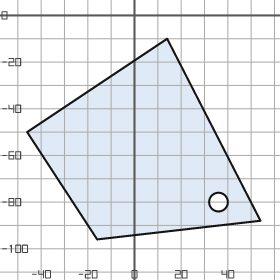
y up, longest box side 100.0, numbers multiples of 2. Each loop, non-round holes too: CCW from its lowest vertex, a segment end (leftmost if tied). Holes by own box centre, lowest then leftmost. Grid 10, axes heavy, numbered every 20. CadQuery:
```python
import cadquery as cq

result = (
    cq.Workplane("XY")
    .moveTo(-16.0, -96.0)
    .lineTo(54.0, -88.0)
    .lineTo(14.0, -10.0)
    .lineTo(-46.0, -50.0)
    .close()
    .moveTo(36.0, -80.0)
    .circle(4.0)
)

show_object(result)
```